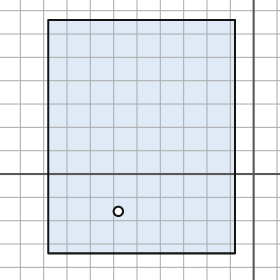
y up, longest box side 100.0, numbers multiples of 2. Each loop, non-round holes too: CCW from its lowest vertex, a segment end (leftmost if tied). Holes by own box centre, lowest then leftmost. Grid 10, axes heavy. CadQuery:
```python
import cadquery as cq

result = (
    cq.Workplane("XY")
    .moveTo(-88.0, -34.0)
    .lineTo(-8.0, -34.0)
    .lineTo(-8.0, 66.0)
    .lineTo(-88.0, 66.0)
    .close()
    .moveTo(-58.0, -16.0)
    .circle(2.0)
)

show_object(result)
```